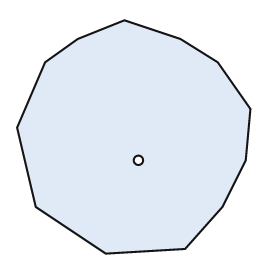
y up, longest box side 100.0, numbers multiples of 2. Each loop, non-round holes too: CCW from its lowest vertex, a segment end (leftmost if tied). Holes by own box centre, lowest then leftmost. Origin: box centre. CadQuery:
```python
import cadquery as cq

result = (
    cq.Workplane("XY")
    .moveTo(-12.0, -50.0)
    .lineTo(22.0, -48.0)
    .lineTo(38.0, -30.0)
    .lineTo(48.0, -10.0)
    .lineTo(50.0, 12.0)
    .lineTo(36.0, 32.0)
    .lineTo(20.0, 42.0)
    .lineTo(-4.0, 50.0)
    .lineTo(-24.0, 42.0)
    .lineTo(-38.0, 32.0)
    .lineTo(-50.0, 4.0)
    .lineTo(-42.0, -30.0)
    .close()
    .moveTo(2.0, -10.0)
    .circle(2.0)
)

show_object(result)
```